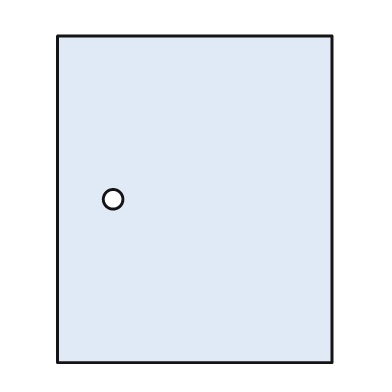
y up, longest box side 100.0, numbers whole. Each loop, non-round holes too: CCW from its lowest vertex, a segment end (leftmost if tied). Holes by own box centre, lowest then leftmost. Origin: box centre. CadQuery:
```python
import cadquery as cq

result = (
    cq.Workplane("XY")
    .moveTo(-42.0, -50.0)
    .lineTo(42.0, -50.0)
    .lineTo(42.0, 50.0)
    .lineTo(-42.0, 50.0)
    .close()
    .moveTo(-25.0, 0.0)
    .circle(3.0)
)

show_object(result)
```